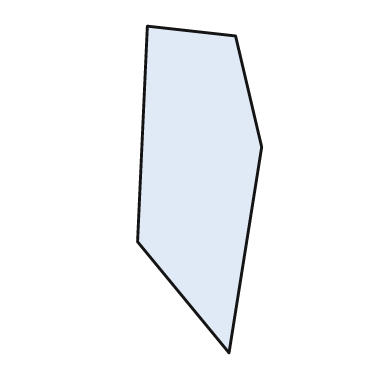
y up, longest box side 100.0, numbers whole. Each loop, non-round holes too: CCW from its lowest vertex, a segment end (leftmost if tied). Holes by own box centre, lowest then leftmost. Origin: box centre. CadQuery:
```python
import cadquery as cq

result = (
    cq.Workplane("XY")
    .moveTo(9.0, -50.0)
    .lineTo(19.0, 13.0)
    .lineTo(11.0, 47.0)
    .lineTo(-16.0, 50.0)
    .lineTo(-19.0, -16.0)
    .close()
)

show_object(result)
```